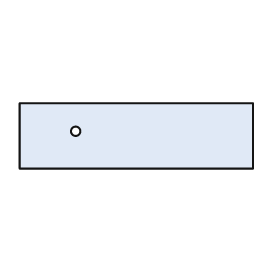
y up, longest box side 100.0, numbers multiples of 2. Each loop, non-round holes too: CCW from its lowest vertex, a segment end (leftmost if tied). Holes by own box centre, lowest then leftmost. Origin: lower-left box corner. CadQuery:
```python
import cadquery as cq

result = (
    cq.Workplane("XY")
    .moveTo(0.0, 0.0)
    .lineTo(100.0, 0.0)
    .lineTo(100.0, 28.0)
    .lineTo(0.0, 28.0)
    .close()
    .moveTo(24.0, 16.0)
    .circle(2.0)
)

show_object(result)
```